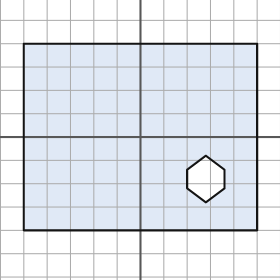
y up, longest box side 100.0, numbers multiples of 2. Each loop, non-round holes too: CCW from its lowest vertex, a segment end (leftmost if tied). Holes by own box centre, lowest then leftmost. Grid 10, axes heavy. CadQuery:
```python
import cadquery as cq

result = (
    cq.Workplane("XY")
    .moveTo(-50.0, -40.0)
    .lineTo(50.0, -40.0)
    .lineTo(50.0, 40.0)
    .lineTo(-50.0, 40.0)
    .close()
    .moveTo(28.0, -28.0)
    .lineTo(36.0, -22.0)
    .lineTo(36.0, -14.0)
    .lineTo(28.0, -8.0)
    .lineTo(20.0, -14.0)
    .lineTo(20.0, -22.0)
    .close()
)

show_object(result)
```